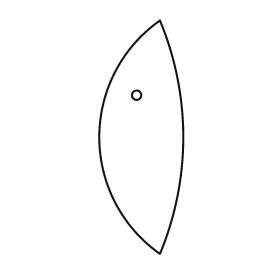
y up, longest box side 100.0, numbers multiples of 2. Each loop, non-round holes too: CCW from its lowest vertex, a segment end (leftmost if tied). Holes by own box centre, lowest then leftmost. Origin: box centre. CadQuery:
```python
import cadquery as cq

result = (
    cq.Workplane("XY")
    .moveTo(8.0, -50.0)
    .threePointArc((18.0, 0.0), (8.0, 50.0))
    .threePointArc((-18.0, 0.0), (8.0, -50.0))
    .close()
    .moveTo(-2.0, 18.0)
    .circle(2.0)
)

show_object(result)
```